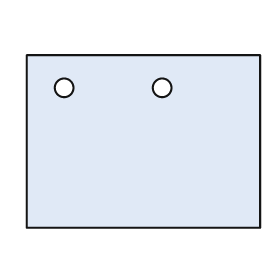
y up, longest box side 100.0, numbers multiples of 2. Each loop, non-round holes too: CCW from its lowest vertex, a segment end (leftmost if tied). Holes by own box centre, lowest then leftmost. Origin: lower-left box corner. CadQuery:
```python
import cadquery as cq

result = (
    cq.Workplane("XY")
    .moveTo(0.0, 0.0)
    .lineTo(100.0, 0.0)
    .lineTo(100.0, 74.0)
    .lineTo(0.0, 74.0)
    .close()
    .moveTo(16.0, 60.0)
    .circle(4.0)
    .moveTo(58.0, 60.0)
    .circle(4.0)
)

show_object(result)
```